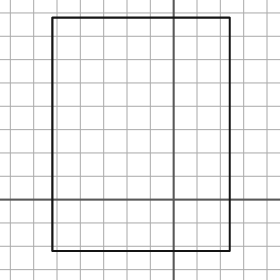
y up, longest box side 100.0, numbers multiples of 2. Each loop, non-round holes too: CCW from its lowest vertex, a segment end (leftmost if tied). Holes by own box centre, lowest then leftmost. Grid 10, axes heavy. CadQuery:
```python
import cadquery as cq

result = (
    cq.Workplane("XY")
    .moveTo(-52.0, -22.0)
    .lineTo(24.0, -22.0)
    .lineTo(24.0, 78.0)
    .lineTo(-52.0, 78.0)
    .close()
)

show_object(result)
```